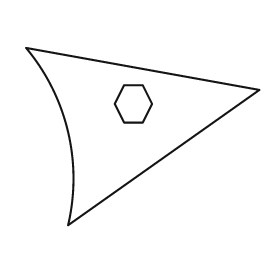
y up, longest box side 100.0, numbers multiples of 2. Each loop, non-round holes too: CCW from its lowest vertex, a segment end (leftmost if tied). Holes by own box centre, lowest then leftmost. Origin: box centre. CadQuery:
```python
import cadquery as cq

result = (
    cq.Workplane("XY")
    .moveTo(-32.0, -38.0)
    .lineTo(50.0, 20.0)
    .lineTo(-50.0, 38.0)
    .threePointArc((-32.0, 2.0), (-32.0, -38.0))
    .close()
    .moveTo(-8.0, 6.0)
    .lineTo(0.0, 6.0)
    .lineTo(4.0, 14.0)
    .lineTo(0.0, 22.0)
    .lineTo(-8.0, 22.0)
    .lineTo(-12.0, 14.0)
    .close()
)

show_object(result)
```